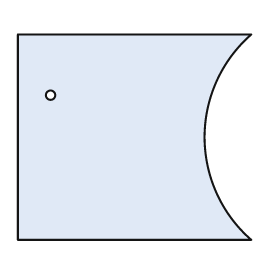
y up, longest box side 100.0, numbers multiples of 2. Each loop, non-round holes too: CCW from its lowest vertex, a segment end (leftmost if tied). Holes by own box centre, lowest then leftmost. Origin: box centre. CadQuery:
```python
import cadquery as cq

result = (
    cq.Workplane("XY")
    .moveTo(-50.0, -44.0)
    .lineTo(50.0, -44.0)
    .threePointArc((30.0, 0.0), (50.0, 44.0))
    .lineTo(-50.0, 44.0)
    .close()
    .moveTo(-36.0, 18.0)
    .circle(2.0)
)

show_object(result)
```